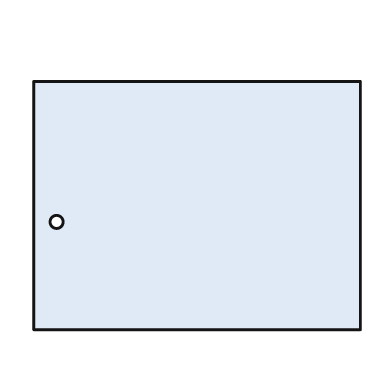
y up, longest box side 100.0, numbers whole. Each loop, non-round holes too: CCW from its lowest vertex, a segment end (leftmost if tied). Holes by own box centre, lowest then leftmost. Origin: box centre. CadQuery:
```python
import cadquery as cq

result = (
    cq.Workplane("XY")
    .moveTo(-50.0, -38.0)
    .lineTo(50.0, -38.0)
    .lineTo(50.0, 38.0)
    .lineTo(-50.0, 38.0)
    .close()
    .moveTo(-43.0, -5.0)
    .circle(2.0)
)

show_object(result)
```